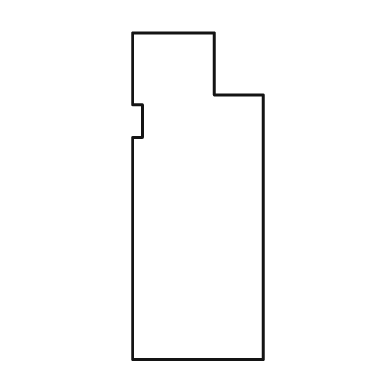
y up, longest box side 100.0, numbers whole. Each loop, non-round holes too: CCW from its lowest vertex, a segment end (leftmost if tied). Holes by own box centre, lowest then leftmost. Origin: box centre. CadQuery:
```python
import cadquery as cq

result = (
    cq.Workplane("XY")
    .moveTo(-20.0, -50.0)
    .lineTo(20.0, -50.0)
    .lineTo(20.0, 31.0)
    .lineTo(5.0, 31.0)
    .lineTo(5.0, 50.0)
    .lineTo(-20.0, 50.0)
    .lineTo(-20.0, 28.0)
    .lineTo(-17.0, 28.0)
    .lineTo(-17.0, 18.0)
    .lineTo(-20.0, 18.0)
    .close()
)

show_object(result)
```